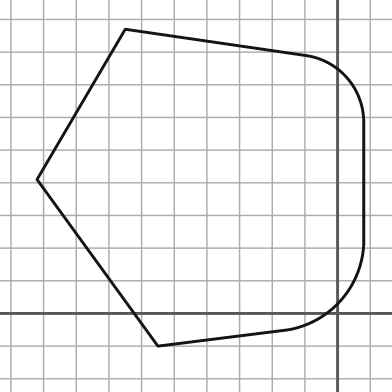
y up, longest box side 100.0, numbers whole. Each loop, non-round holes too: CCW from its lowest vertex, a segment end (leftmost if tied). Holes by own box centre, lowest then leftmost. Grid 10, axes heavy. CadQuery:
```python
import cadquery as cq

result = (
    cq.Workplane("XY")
    .moveTo(-55.0, -10.0)
    .lineTo(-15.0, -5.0)
    .threePointArc((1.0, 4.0), (8.0, 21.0))
    .lineTo(8.0, 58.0)
    .threePointArc((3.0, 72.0), (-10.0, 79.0))
    .lineTo(-65.0, 87.0)
    .lineTo(-92.0, 41.0)
    .close()
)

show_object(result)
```